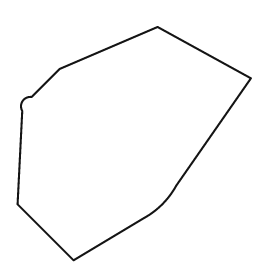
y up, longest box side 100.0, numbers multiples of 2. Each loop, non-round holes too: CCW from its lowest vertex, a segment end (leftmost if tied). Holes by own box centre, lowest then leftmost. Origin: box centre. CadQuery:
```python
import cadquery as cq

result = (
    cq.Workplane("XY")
    .moveTo(-26.0, -50.0)
    .lineTo(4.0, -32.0)
    .threePointArc((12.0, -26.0), (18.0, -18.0))
    .lineTo(50.0, 28.0)
    .lineTo(10.0, 50.0)
    .lineTo(-32.0, 32.0)
    .lineTo(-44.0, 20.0)
    .threePointArc((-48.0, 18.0), (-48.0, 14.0))
    .lineTo(-50.0, -26.0)
    .close()
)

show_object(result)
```